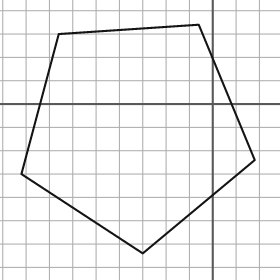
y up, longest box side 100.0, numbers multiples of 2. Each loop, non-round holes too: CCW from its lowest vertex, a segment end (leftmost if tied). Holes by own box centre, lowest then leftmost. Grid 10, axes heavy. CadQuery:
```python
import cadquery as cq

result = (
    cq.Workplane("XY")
    .moveTo(-30.0, -64.0)
    .lineTo(18.0, -24.0)
    .lineTo(-6.0, 34.0)
    .lineTo(-66.0, 30.0)
    .lineTo(-82.0, -30.0)
    .close()
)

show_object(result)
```